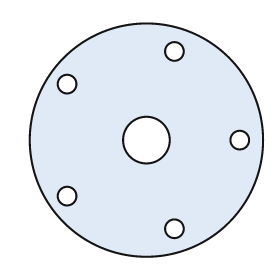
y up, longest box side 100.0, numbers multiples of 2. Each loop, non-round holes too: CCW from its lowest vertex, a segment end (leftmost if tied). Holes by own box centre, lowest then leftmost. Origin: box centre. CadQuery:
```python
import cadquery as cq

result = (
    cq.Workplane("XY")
    .moveTo(0.0, 0.0)
    .circle(50.0)
    .moveTo(12.0, -38.0)
    .circle(4.0)
    .moveTo(-34.0, -24.0)
    .circle(4.0)
    .moveTo(0.0, 0.0)
    .circle(10.0)
    .moveTo(40.0, 0.0)
    .circle(4.0)
    .moveTo(-34.0, 24.0)
    .circle(4.0)
    .moveTo(12.0, 38.0)
    .circle(4.0)
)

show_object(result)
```